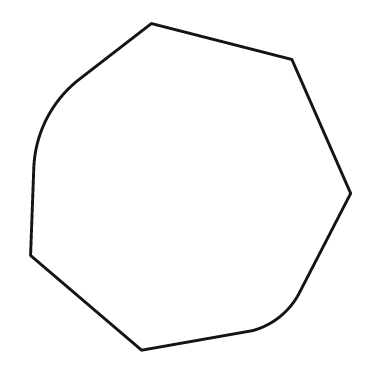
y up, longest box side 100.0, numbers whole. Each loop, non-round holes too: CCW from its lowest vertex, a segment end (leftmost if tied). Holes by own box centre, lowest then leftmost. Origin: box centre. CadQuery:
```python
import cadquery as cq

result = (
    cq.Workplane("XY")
    .moveTo(-15.0, -50.0)
    .lineTo(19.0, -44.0)
    .threePointArc((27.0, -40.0), (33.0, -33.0))
    .lineTo(49.0, -2.0)
    .lineTo(31.0, 39.0)
    .lineTo(-12.0, 50.0)
    .lineTo(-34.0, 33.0)
    .threePointArc((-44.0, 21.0), (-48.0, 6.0))
    .lineTo(-49.0, -21.0)
    .close()
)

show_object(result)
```